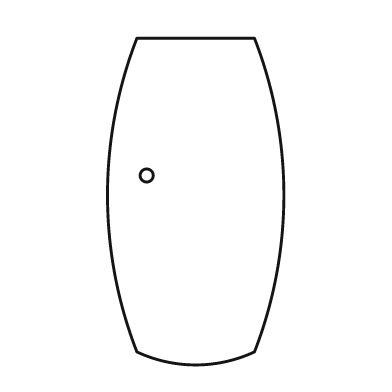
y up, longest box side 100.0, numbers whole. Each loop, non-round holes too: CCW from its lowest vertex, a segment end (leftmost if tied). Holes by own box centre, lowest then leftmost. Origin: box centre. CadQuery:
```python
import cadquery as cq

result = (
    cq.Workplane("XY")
    .moveTo(-18.0, -46.0)
    .threePointArc((0.0, -50.0), (18.0, -46.0))
    .threePointArc((27.0, 2.0), (18.0, 50.0))
    .lineTo(-18.0, 50.0)
    .threePointArc((-27.0, 2.0), (-18.0, -46.0))
    .close()
    .moveTo(-15.0, 8.0)
    .circle(2.0)
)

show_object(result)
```